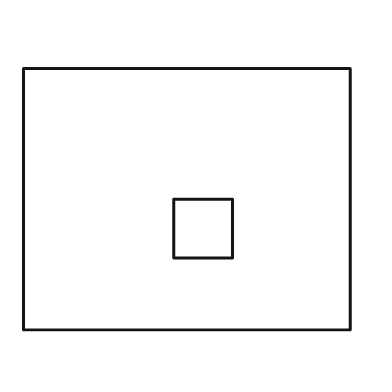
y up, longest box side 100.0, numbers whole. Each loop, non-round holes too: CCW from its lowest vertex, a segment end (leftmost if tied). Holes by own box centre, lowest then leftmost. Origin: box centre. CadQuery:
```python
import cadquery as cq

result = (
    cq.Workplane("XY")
    .moveTo(-50.0, -40.0)
    .lineTo(50.0, -40.0)
    .lineTo(50.0, 40.0)
    .lineTo(-50.0, 40.0)
    .close()
    .moveTo(-4.0, -18.0)
    .lineTo(14.0, -18.0)
    .lineTo(14.0, 0.0)
    .lineTo(-4.0, 0.0)
    .close()
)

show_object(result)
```